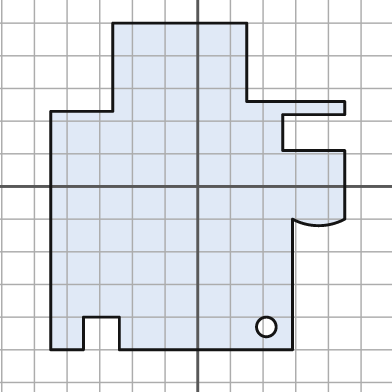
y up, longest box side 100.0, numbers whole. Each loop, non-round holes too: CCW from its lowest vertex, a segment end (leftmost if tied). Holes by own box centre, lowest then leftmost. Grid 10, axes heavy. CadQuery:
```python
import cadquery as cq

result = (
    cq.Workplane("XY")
    .moveTo(-45.0, -50.0)
    .lineTo(-35.0, -50.0)
    .lineTo(-35.0, -40.0)
    .lineTo(-24.0, -40.0)
    .lineTo(-24.0, -50.0)
    .lineTo(29.0, -50.0)
    .lineTo(29.0, -10.0)
    .threePointArc((37.0, -12.0), (45.0, -10.0))
    .lineTo(45.0, 11.0)
    .lineTo(26.0, 11.0)
    .lineTo(26.0, 22.0)
    .lineTo(45.0, 22.0)
    .lineTo(45.0, 26.0)
    .lineTo(15.0, 26.0)
    .lineTo(15.0, 50.0)
    .lineTo(-26.0, 50.0)
    .lineTo(-26.0, 23.0)
    .lineTo(-45.0, 23.0)
    .close()
    .moveTo(21.0, -43.0)
    .circle(3.0)
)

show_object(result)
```